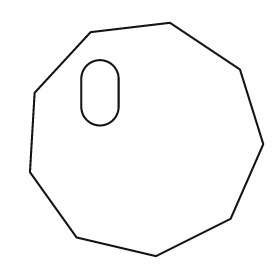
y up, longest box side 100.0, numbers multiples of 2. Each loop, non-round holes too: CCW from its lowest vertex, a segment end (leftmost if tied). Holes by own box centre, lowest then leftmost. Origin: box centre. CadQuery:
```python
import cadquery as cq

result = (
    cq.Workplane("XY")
    .moveTo(4.0, -50.0)
    .lineTo(36.0, -34.0)
    .lineTo(50.0, -2.0)
    .lineTo(40.0, 30.0)
    .lineTo(10.0, 50.0)
    .lineTo(-24.0, 46.0)
    .lineTo(-48.0, 20.0)
    .lineTo(-50.0, -14.0)
    .lineTo(-30.0, -42.0)
    .close()
    .moveTo(-28.0, 14.0)
    .threePointArc((-20.0, 6.0), (-12.0, 14.0))
    .lineTo(-12.0, 26.0)
    .threePointArc((-20.0, 34.0), (-28.0, 26.0))
    .close()
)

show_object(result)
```